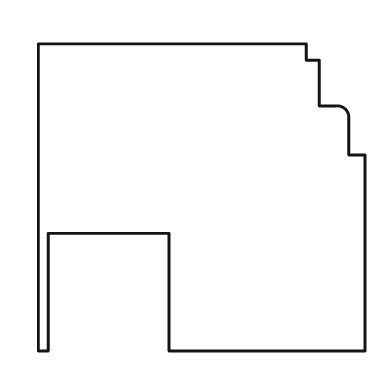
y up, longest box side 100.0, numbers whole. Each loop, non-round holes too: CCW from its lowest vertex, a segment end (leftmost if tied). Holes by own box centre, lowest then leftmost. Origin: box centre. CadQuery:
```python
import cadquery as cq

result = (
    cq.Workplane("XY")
    .moveTo(-50.0, -47.0)
    .lineTo(-47.0, -47.0)
    .lineTo(-47.0, -11.0)
    .lineTo(-10.0, -11.0)
    .lineTo(-10.0, -47.0)
    .lineTo(50.0, -47.0)
    .lineTo(50.0, 13.0)
    .lineTo(45.0, 13.0)
    .lineTo(45.0, 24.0)
    .threePointArc((44.0, 27.0), (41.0, 28.0))
    .lineTo(36.0, 28.0)
    .lineTo(36.0, 42.0)
    .lineTo(32.0, 42.0)
    .lineTo(32.0, 47.0)
    .lineTo(-50.0, 47.0)
    .close()
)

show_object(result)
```